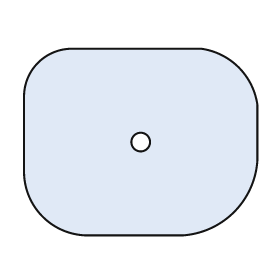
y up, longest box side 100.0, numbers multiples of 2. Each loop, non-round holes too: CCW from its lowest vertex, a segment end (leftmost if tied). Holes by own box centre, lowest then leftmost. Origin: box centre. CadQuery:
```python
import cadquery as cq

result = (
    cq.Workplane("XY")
    .moveTo(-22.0, -40.0)
    .lineTo(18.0, -40.0)
    .threePointArc((40.0, -30.0), (50.0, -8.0))
    .lineTo(50.0, 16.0)
    .threePointArc((42.0, 32.0), (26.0, 40.0))
    .lineTo(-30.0, 40.0)
    .threePointArc((-44.0, 34.0), (-50.0, 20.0))
    .lineTo(-50.0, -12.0)
    .threePointArc((-42.0, -32.0), (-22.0, -40.0))
    .close()
    .moveTo(0.0, 0.0)
    .circle(4.0)
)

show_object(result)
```